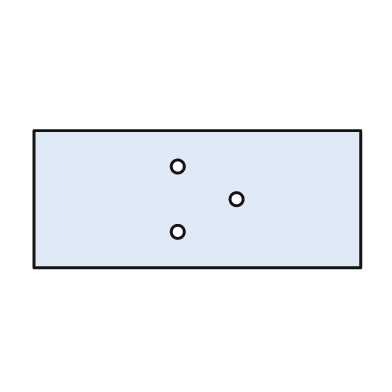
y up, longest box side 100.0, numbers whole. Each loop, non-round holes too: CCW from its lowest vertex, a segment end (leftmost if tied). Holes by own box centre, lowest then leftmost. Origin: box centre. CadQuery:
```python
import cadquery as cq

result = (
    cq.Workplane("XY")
    .moveTo(-50.0, -21.0)
    .lineTo(50.0, -21.0)
    .lineTo(50.0, 21.0)
    .lineTo(-50.0, 21.0)
    .close()
    .moveTo(-6.0, -10.0)
    .circle(2.0)
    .moveTo(12.0, 0.0)
    .circle(2.0)
    .moveTo(-6.0, 10.0)
    .circle(2.0)
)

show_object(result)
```